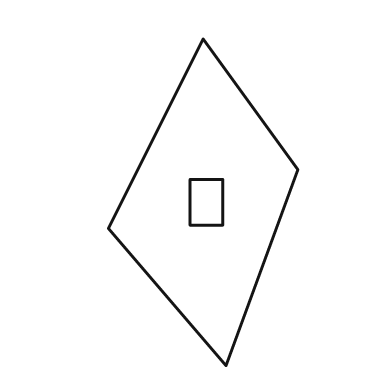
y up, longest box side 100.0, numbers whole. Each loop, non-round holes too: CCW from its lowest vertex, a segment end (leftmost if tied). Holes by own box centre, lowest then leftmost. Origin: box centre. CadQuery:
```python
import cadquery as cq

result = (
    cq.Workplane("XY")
    .moveTo(7.0, -50.0)
    .lineTo(29.0, 10.0)
    .lineTo(0.0, 50.0)
    .lineTo(-29.0, -8.0)
    .close()
    .moveTo(-4.0, -7.0)
    .lineTo(6.0, -7.0)
    .lineTo(6.0, 7.0)
    .lineTo(-4.0, 7.0)
    .close()
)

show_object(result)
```